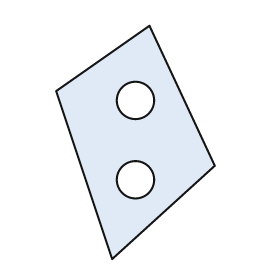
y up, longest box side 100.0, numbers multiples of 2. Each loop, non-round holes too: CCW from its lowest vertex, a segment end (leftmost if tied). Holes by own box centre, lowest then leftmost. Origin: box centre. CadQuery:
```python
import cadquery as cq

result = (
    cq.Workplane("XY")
    .moveTo(-10.0, -50.0)
    .lineTo(34.0, -10.0)
    .lineTo(6.0, 50.0)
    .lineTo(-34.0, 22.0)
    .close()
    .moveTo(0.0, -16.0)
    .circle(8.0)
    .moveTo(0.0, 18.0)
    .circle(8.0)
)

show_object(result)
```